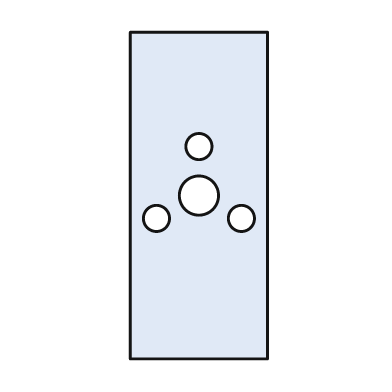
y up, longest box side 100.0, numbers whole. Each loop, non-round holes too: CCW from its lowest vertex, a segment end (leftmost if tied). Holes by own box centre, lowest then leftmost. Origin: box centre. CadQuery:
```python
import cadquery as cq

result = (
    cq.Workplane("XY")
    .moveTo(-21.0, -50.0)
    .lineTo(21.0, -50.0)
    .lineTo(21.0, 50.0)
    .lineTo(-21.0, 50.0)
    .close()
    .moveTo(-13.0, -7.0)
    .circle(4.0)
    .moveTo(13.0, -7.0)
    .circle(4.0)
    .moveTo(0.0, 0.0)
    .circle(6.0)
    .moveTo(0.0, 15.0)
    .circle(4.0)
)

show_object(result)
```